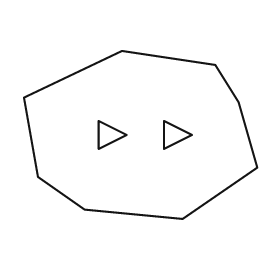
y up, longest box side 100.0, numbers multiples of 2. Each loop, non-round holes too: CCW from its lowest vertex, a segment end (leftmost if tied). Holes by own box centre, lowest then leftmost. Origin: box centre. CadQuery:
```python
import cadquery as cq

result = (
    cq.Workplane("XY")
    .moveTo(18.0, -36.0)
    .lineTo(50.0, -14.0)
    .lineTo(42.0, 14.0)
    .lineTo(32.0, 30.0)
    .lineTo(-8.0, 36.0)
    .lineTo(-50.0, 16.0)
    .lineTo(-44.0, -18.0)
    .lineTo(-24.0, -32.0)
    .close()
    .moveTo(-18.0, -6.0)
    .lineTo(-6.0, 0.0)
    .lineTo(-18.0, 6.0)
    .close()
    .moveTo(10.0, -6.0)
    .lineTo(22.0, 0.0)
    .lineTo(10.0, 6.0)
    .close()
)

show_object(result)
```